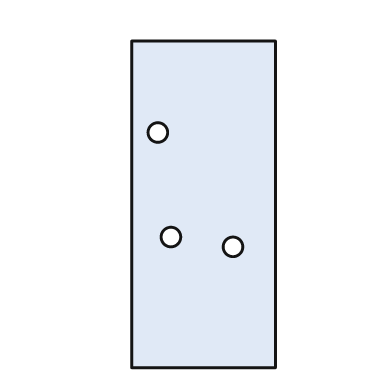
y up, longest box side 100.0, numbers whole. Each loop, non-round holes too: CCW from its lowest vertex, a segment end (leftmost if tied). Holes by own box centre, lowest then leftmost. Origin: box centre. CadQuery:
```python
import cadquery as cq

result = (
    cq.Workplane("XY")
    .moveTo(-22.0, -50.0)
    .lineTo(22.0, -50.0)
    .lineTo(22.0, 50.0)
    .lineTo(-22.0, 50.0)
    .close()
    .moveTo(9.0, -13.0)
    .circle(3.0)
    .moveTo(-10.0, -10.0)
    .circle(3.0)
    .moveTo(-14.0, 22.0)
    .circle(3.0)
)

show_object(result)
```